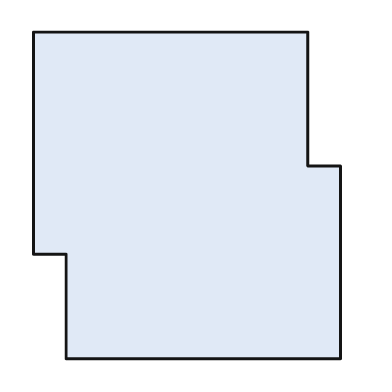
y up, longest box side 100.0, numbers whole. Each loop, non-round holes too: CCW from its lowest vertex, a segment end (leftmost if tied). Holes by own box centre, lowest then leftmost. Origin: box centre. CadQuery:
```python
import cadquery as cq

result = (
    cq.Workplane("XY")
    .moveTo(-37.0, -50.0)
    .lineTo(47.0, -50.0)
    .lineTo(47.0, 9.0)
    .lineTo(37.0, 9.0)
    .lineTo(37.0, 50.0)
    .lineTo(-47.0, 50.0)
    .lineTo(-47.0, -18.0)
    .lineTo(-37.0, -18.0)
    .close()
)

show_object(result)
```